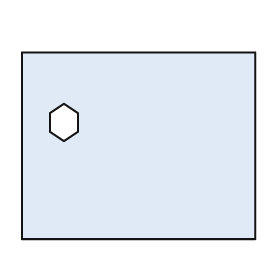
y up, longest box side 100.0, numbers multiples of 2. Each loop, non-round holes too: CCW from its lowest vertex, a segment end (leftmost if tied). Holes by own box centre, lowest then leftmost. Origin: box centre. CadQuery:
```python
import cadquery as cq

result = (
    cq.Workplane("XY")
    .moveTo(-50.0, -40.0)
    .lineTo(50.0, -40.0)
    .lineTo(50.0, 40.0)
    .lineTo(-50.0, 40.0)
    .close()
    .moveTo(-32.0, 2.0)
    .lineTo(-26.0, 6.0)
    .lineTo(-26.0, 14.0)
    .lineTo(-32.0, 18.0)
    .lineTo(-38.0, 14.0)
    .lineTo(-38.0, 6.0)
    .close()
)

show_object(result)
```